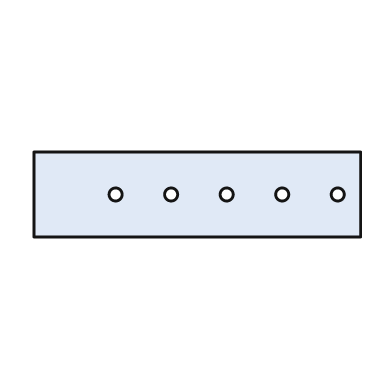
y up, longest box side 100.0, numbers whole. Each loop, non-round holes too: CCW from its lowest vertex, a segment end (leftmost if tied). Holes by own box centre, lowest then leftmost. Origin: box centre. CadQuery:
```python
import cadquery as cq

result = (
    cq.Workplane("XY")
    .moveTo(-50.0, -13.0)
    .lineTo(50.0, -13.0)
    .lineTo(50.0, 13.0)
    .lineTo(-50.0, 13.0)
    .close()
    .moveTo(-25.0, 0.0)
    .circle(2.0)
    .moveTo(-8.0, 0.0)
    .circle(2.0)
    .moveTo(9.0, 0.0)
    .circle(2.0)
    .moveTo(26.0, 0.0)
    .circle(2.0)
    .moveTo(43.0, 0.0)
    .circle(2.0)
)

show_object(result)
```